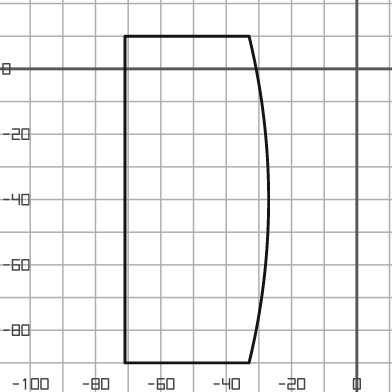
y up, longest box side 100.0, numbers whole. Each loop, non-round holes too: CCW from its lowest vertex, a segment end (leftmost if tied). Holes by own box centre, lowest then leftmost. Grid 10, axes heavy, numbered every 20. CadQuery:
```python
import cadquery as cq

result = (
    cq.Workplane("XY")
    .moveTo(-71.0, -90.0)
    .lineTo(-33.0, -90.0)
    .threePointArc((-27.0, -40.0), (-33.0, 10.0))
    .lineTo(-71.0, 10.0)
    .close()
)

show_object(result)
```